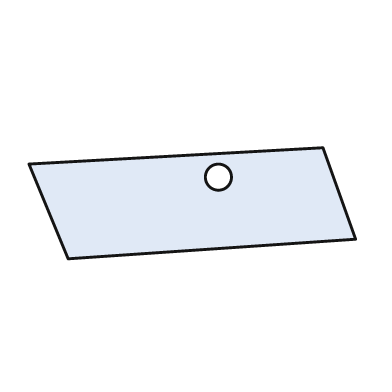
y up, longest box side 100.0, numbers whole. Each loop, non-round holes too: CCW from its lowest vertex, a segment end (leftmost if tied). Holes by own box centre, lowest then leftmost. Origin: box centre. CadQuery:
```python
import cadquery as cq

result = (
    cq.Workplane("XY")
    .moveTo(-38.0, -17.0)
    .lineTo(50.0, -11.0)
    .lineTo(40.0, 17.0)
    .lineTo(-50.0, 12.0)
    .close()
    .moveTo(8.0, 8.0)
    .circle(4.0)
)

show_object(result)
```